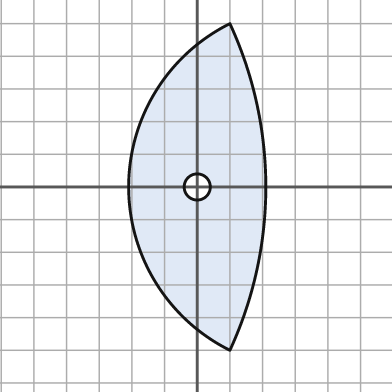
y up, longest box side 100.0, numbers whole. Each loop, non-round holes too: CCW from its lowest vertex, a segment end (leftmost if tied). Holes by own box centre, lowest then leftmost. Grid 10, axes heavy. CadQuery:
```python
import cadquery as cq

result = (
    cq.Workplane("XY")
    .moveTo(10.0, -50.0)
    .threePointArc((21.0, 0.0), (10.0, 50.0))
    .threePointArc((-21.0, 0.0), (10.0, -50.0))
    .close()
    .moveTo(0.0, 0.0)
    .circle(4.0)
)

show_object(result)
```